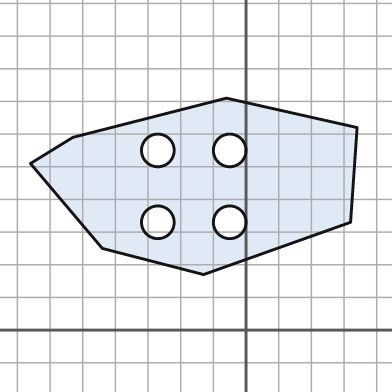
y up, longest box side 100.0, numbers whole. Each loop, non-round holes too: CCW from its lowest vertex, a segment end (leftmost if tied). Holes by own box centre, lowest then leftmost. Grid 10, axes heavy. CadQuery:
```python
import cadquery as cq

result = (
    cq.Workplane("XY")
    .moveTo(-13.0, 17.0)
    .lineTo(32.0, 33.0)
    .lineTo(34.0, 62.0)
    .lineTo(-6.0, 71.0)
    .lineTo(-53.0, 59.0)
    .lineTo(-66.0, 51.0)
    .lineTo(-44.0, 25.0)
    .close()
    .moveTo(-27.0, 33.0)
    .circle(5.0)
    .moveTo(-5.0, 33.0)
    .circle(5.0)
    .moveTo(-27.0, 55.0)
    .circle(5.0)
    .moveTo(-5.0, 55.0)
    .circle(5.0)
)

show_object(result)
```